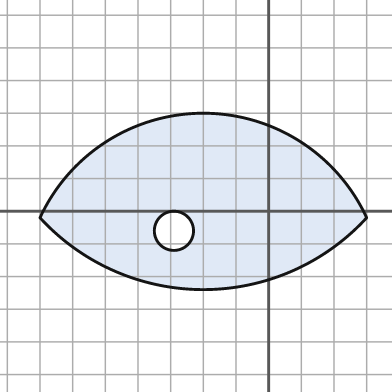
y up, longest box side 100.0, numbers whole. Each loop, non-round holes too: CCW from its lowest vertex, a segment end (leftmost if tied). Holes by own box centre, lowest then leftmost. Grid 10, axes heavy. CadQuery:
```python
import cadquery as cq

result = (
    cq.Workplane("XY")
    .moveTo(-70.0, -2.0)
    .threePointArc((-20.0, -24.0), (30.0, -2.0))
    .threePointArc((-20.0, 30.0), (-70.0, -2.0))
    .close()
    .moveTo(-29.0, -6.0)
    .circle(6.0)
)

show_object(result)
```